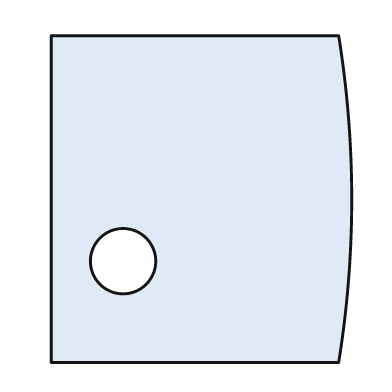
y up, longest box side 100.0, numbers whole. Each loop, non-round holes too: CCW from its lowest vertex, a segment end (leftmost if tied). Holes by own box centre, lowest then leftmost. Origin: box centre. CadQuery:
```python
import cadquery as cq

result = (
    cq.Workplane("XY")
    .moveTo(-46.0, -50.0)
    .lineTo(42.0, -50.0)
    .threePointArc((46.0, 0.0), (42.0, 50.0))
    .lineTo(-46.0, 50.0)
    .close()
    .moveTo(-24.0, -19.0)
    .circle(10.0)
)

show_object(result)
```